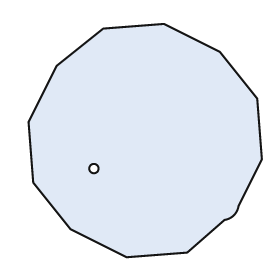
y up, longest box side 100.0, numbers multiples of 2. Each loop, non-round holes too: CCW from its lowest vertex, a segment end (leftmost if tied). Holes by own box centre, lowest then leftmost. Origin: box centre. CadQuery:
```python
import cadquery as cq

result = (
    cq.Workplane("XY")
    .moveTo(-8.0, -50.0)
    .lineTo(18.0, -48.0)
    .lineTo(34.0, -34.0)
    .threePointArc((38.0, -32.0), (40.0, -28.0))
    .lineTo(50.0, -8.0)
    .lineTo(48.0, 18.0)
    .lineTo(32.0, 38.0)
    .lineTo(8.0, 50.0)
    .lineTo(-18.0, 48.0)
    .lineTo(-38.0, 32.0)
    .lineTo(-50.0, 8.0)
    .lineTo(-48.0, -18.0)
    .lineTo(-32.0, -38.0)
    .close()
    .moveTo(-22.0, -12.0)
    .circle(2.0)
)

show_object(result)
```